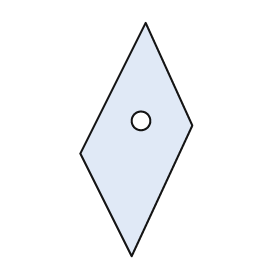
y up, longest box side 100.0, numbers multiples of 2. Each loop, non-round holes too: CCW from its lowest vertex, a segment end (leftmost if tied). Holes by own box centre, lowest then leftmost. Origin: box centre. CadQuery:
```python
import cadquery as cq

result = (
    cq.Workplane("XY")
    .moveTo(-2.0, -50.0)
    .lineTo(24.0, 6.0)
    .lineTo(4.0, 50.0)
    .lineTo(-24.0, -6.0)
    .close()
    .moveTo(2.0, 8.0)
    .circle(4.0)
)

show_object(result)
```